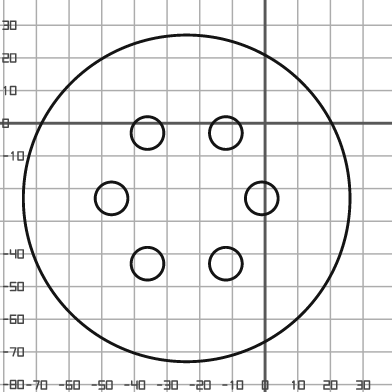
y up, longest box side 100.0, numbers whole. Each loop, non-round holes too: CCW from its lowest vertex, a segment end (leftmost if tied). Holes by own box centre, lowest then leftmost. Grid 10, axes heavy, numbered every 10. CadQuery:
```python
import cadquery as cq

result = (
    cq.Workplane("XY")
    .moveTo(-24.0, -23.0)
    .circle(50.0)
    .moveTo(-36.0, -43.0)
    .circle(5.0)
    .moveTo(-12.0, -43.0)
    .circle(5.0)
    .moveTo(-47.0, -23.0)
    .circle(5.0)
    .moveTo(-1.0, -23.0)
    .circle(5.0)
    .moveTo(-36.0, -3.0)
    .circle(5.0)
    .moveTo(-12.0, -3.0)
    .circle(5.0)
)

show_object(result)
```